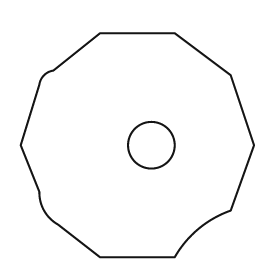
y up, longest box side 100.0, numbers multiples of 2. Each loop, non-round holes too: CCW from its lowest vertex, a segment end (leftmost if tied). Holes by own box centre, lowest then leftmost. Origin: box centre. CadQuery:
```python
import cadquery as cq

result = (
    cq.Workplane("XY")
    .moveTo(-16.0, -48.0)
    .lineTo(16.0, -48.0)
    .threePointArc((26.0, -36.0), (40.0, -28.0))
    .lineTo(50.0, 0.0)
    .lineTo(40.0, 30.0)
    .lineTo(16.0, 48.0)
    .lineTo(-16.0, 48.0)
    .lineTo(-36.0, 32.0)
    .threePointArc((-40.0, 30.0), (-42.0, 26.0))
    .lineTo(-50.0, 0.0)
    .lineTo(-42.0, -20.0)
    .threePointArc((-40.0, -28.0), (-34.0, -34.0))
    .close()
    .moveTo(6.0, 0.0)
    .circle(10.0)
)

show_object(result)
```